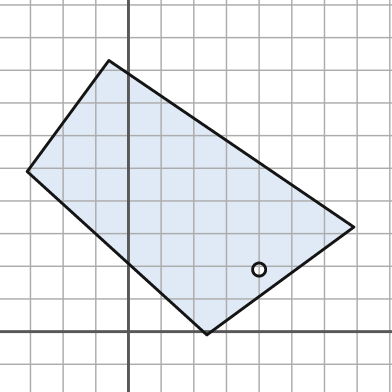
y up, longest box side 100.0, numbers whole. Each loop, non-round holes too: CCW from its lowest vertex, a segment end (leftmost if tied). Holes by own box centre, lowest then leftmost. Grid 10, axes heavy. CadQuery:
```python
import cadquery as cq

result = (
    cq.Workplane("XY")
    .moveTo(24.0, -1.0)
    .lineTo(69.0, 32.0)
    .lineTo(-6.0, 83.0)
    .lineTo(-31.0, 49.0)
    .close()
    .moveTo(40.0, 19.0)
    .circle(2.0)
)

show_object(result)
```